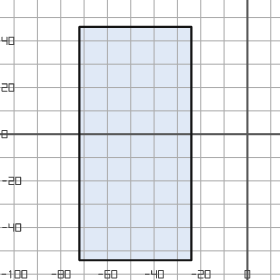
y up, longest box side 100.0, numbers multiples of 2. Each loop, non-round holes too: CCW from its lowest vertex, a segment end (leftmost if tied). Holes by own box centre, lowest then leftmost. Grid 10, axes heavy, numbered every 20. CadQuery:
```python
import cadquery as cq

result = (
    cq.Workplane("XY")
    .moveTo(-72.0, -54.0)
    .lineTo(-24.0, -54.0)
    .lineTo(-24.0, 46.0)
    .lineTo(-72.0, 46.0)
    .close()
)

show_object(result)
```